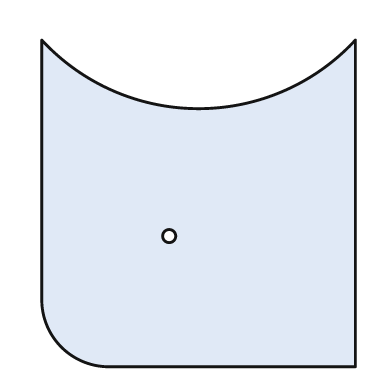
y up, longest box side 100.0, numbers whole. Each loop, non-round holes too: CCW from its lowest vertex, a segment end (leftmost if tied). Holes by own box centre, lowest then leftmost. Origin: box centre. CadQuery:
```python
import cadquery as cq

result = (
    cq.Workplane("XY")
    .moveTo(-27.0, -50.0)
    .lineTo(48.0, -50.0)
    .lineTo(48.0, 50.0)
    .threePointArc((0.0, 29.0), (-48.0, 50.0))
    .lineTo(-48.0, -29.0)
    .threePointArc((-42.0, -44.0), (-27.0, -50.0))
    .close()
    .moveTo(-9.0, -10.0)
    .circle(2.0)
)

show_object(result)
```